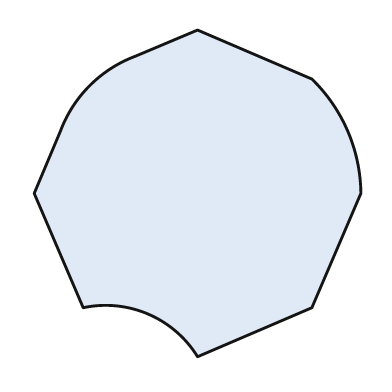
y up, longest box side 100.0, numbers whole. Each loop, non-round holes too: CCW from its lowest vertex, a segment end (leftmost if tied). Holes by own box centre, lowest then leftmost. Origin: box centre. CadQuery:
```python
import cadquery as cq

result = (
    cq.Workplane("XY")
    .moveTo(0.0, -50.0)
    .lineTo(35.0, -35.0)
    .lineTo(50.0, 0.0)
    .threePointArc((46.0, 19.0), (35.0, 35.0))
    .lineTo(0.0, 50.0)
    .lineTo(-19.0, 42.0)
    .threePointArc((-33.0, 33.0), (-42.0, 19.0))
    .lineTo(-50.0, 0.0)
    .lineTo(-35.0, -35.0)
    .threePointArc((-15.0, -37.0), (0.0, -50.0))
    .close()
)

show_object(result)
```